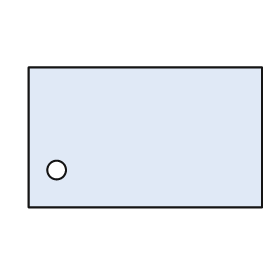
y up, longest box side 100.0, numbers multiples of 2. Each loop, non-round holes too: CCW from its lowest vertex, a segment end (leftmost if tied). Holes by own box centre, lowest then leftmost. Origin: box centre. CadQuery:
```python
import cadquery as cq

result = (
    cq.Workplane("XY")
    .moveTo(-50.0, -30.0)
    .lineTo(50.0, -30.0)
    .lineTo(50.0, 30.0)
    .lineTo(-50.0, 30.0)
    .close()
    .moveTo(-38.0, -14.0)
    .circle(4.0)
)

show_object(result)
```